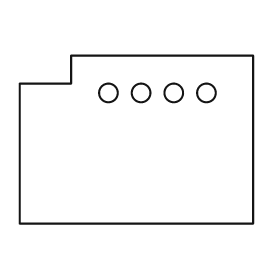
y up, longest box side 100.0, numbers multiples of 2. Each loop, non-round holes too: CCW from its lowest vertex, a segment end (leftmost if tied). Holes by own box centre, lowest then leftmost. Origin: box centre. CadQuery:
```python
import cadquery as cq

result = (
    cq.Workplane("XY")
    .moveTo(-50.0, -36.0)
    .lineTo(50.0, -36.0)
    .lineTo(50.0, 36.0)
    .lineTo(-28.0, 36.0)
    .lineTo(-28.0, 24.0)
    .lineTo(-50.0, 24.0)
    .close()
    .moveTo(-12.0, 20.0)
    .circle(4.0)
    .moveTo(2.0, 20.0)
    .circle(4.0)
    .moveTo(16.0, 20.0)
    .circle(4.0)
    .moveTo(30.0, 20.0)
    .circle(4.0)
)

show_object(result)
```